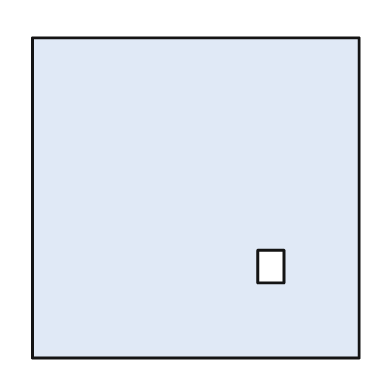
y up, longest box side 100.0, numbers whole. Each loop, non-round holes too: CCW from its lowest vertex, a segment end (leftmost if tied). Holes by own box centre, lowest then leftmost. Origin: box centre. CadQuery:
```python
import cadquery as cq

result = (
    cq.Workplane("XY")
    .moveTo(-50.0, -49.0)
    .lineTo(50.0, -49.0)
    .lineTo(50.0, 49.0)
    .lineTo(-50.0, 49.0)
    .close()
    .moveTo(19.0, -26.0)
    .lineTo(27.0, -26.0)
    .lineTo(27.0, -16.0)
    .lineTo(19.0, -16.0)
    .close()
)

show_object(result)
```